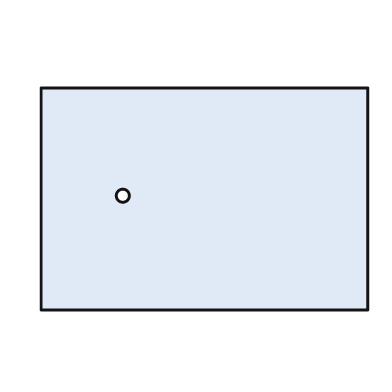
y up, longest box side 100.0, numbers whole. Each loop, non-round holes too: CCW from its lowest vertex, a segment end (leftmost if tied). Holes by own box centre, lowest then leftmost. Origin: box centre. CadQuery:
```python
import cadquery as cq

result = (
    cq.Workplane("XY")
    .moveTo(-50.0, -34.0)
    .lineTo(50.0, -34.0)
    .lineTo(50.0, 34.0)
    .lineTo(-50.0, 34.0)
    .close()
    .moveTo(-25.0, 1.0)
    .circle(2.0)
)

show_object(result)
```